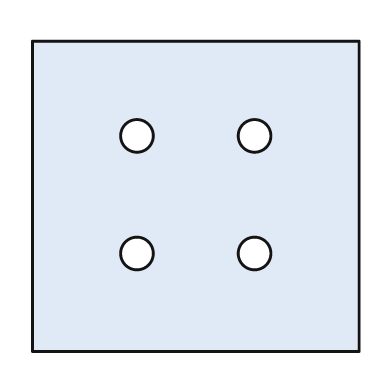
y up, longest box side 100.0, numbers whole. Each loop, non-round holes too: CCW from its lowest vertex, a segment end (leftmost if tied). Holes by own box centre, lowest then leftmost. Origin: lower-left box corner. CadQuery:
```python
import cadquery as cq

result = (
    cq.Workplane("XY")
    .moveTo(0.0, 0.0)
    .lineTo(100.0, 0.0)
    .lineTo(100.0, 95.0)
    .lineTo(0.0, 95.0)
    .close()
    .moveTo(32.0, 30.0)
    .circle(5.0)
    .moveTo(68.0, 30.0)
    .circle(5.0)
    .moveTo(32.0, 66.0)
    .circle(5.0)
    .moveTo(68.0, 66.0)
    .circle(5.0)
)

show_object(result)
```